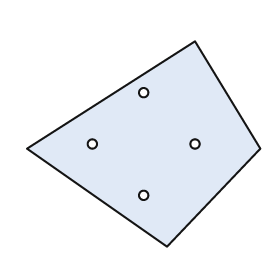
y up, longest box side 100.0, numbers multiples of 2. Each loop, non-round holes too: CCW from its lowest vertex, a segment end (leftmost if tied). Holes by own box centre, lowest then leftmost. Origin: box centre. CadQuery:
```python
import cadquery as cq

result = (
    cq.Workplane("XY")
    .moveTo(10.0, -44.0)
    .lineTo(50.0, -2.0)
    .lineTo(22.0, 44.0)
    .lineTo(-50.0, -2.0)
    .close()
    .moveTo(0.0, -22.0)
    .circle(2.0)
    .moveTo(-22.0, 0.0)
    .circle(2.0)
    .moveTo(22.0, 0.0)
    .circle(2.0)
    .moveTo(0.0, 22.0)
    .circle(2.0)
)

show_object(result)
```